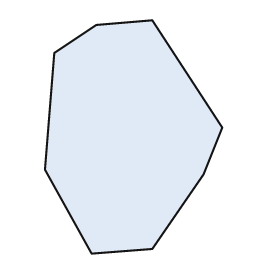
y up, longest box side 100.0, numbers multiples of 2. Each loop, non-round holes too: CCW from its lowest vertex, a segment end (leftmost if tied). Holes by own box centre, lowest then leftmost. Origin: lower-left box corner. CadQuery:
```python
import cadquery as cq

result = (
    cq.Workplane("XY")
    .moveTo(20.0, 0.0)
    .lineTo(46.0, 2.0)
    .lineTo(68.0, 34.0)
    .lineTo(76.0, 54.0)
    .lineTo(46.0, 100.0)
    .lineTo(22.0, 98.0)
    .lineTo(4.0, 86.0)
    .lineTo(0.0, 36.0)
    .close()
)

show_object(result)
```